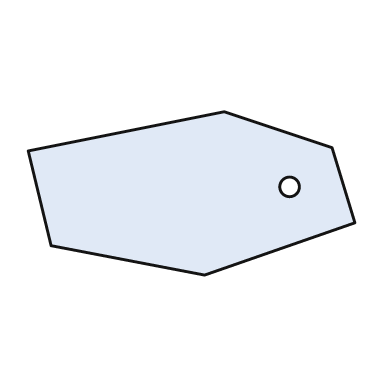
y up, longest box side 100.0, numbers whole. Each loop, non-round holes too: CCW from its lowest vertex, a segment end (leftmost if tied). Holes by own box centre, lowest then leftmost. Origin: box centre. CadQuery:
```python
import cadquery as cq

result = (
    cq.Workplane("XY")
    .moveTo(4.0, -25.0)
    .lineTo(50.0, -9.0)
    .lineTo(43.0, 14.0)
    .lineTo(10.0, 25.0)
    .lineTo(-50.0, 13.0)
    .lineTo(-43.0, -16.0)
    .close()
    .moveTo(30.0, 2.0)
    .circle(3.0)
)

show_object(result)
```